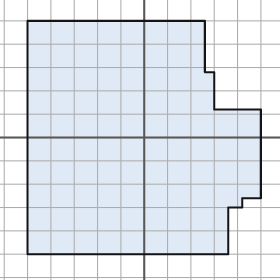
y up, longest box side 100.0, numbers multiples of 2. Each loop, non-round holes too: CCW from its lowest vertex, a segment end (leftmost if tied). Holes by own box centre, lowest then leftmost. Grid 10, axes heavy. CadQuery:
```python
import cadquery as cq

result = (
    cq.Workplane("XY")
    .moveTo(-50.0, -50.0)
    .lineTo(36.0, -50.0)
    .lineTo(36.0, -30.0)
    .lineTo(42.0, -30.0)
    .lineTo(42.0, -26.0)
    .lineTo(50.0, -26.0)
    .lineTo(50.0, 12.0)
    .lineTo(30.0, 12.0)
    .lineTo(30.0, 28.0)
    .lineTo(26.0, 28.0)
    .lineTo(26.0, 50.0)
    .lineTo(-50.0, 50.0)
    .close()
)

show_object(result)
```